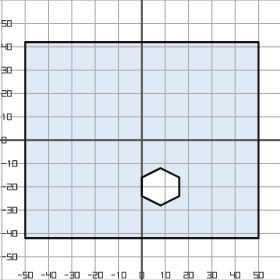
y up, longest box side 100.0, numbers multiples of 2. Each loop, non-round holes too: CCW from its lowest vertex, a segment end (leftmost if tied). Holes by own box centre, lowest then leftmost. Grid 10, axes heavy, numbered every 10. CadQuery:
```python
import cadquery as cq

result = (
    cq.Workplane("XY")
    .moveTo(-50.0, -42.0)
    .lineTo(50.0, -42.0)
    .lineTo(50.0, 42.0)
    .lineTo(-50.0, 42.0)
    .close()
    .moveTo(8.0, -28.0)
    .lineTo(16.0, -24.0)
    .lineTo(16.0, -16.0)
    .lineTo(8.0, -12.0)
    .lineTo(0.0, -16.0)
    .lineTo(0.0, -24.0)
    .close()
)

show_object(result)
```